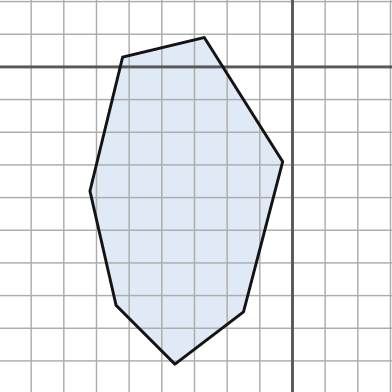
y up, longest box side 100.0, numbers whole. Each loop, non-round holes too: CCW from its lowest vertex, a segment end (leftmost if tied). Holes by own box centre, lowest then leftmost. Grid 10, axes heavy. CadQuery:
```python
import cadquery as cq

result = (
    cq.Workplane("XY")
    .moveTo(-36.0, -91.0)
    .lineTo(-15.0, -75.0)
    .lineTo(-3.0, -29.0)
    .lineTo(-27.0, 9.0)
    .lineTo(-52.0, 3.0)
    .lineTo(-62.0, -38.0)
    .lineTo(-54.0, -73.0)
    .close()
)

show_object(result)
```